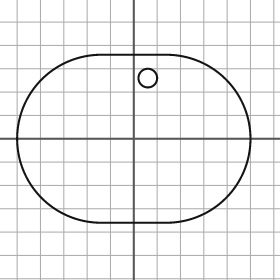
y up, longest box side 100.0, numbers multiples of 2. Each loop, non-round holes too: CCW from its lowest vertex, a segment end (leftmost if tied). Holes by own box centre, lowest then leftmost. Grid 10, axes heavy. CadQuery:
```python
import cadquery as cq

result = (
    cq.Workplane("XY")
    .moveTo(-14.0, -36.0)
    .lineTo(14.0, -36.0)
    .threePointArc((50.0, 0.0), (14.0, 36.0))
    .lineTo(-14.0, 36.0)
    .threePointArc((-50.0, 0.0), (-14.0, -36.0))
    .close()
    .moveTo(6.0, 26.0)
    .circle(4.0)
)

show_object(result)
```